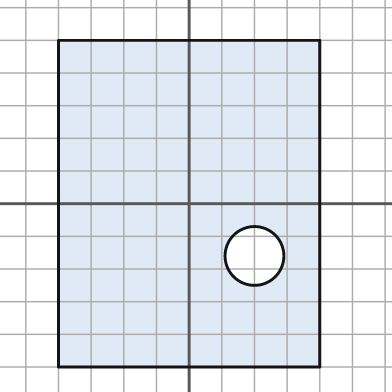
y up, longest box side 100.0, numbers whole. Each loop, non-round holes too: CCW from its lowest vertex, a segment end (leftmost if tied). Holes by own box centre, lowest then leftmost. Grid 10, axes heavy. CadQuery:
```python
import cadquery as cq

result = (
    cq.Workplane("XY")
    .moveTo(-40.0, -50.0)
    .lineTo(40.0, -50.0)
    .lineTo(40.0, 50.0)
    .lineTo(-40.0, 50.0)
    .close()
    .moveTo(20.0, -16.0)
    .circle(9.0)
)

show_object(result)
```